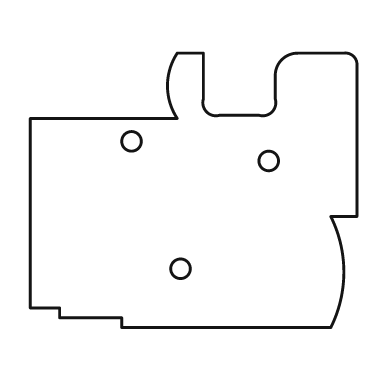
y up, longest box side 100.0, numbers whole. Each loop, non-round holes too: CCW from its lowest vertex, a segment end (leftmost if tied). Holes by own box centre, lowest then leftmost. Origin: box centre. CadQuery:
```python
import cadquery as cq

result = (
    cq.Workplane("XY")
    .moveTo(-22.0, -42.0)
    .lineTo(42.0, -42.0)
    .threePointArc((46.0, -25.0), (42.0, -8.0))
    .lineTo(50.0, -8.0)
    .lineTo(50.0, 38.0)
    .threePointArc((49.0, 41.0), (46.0, 42.0))
    .lineTo(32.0, 42.0)
    .threePointArc((27.0, 40.0), (25.0, 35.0))
    .lineTo(25.0, 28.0)
    .threePointArc((24.0, 24.0), (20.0, 23.0))
    .lineTo(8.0, 23.0)
    .threePointArc((4.0, 24.0), (3.0, 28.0))
    .lineTo(3.0, 42.0)
    .lineTo(-5.0, 42.0)
    .threePointArc((-8.0, 32.0), (-5.0, 22.0))
    .lineTo(-50.0, 22.0)
    .lineTo(-50.0, -36.0)
    .lineTo(-41.0, -36.0)
    .lineTo(-41.0, -39.0)
    .lineTo(-22.0, -39.0)
    .close()
    .moveTo(-4.0, -24.0)
    .circle(3.0)
    .moveTo(23.0, 9.0)
    .circle(3.0)
    .moveTo(-19.0, 15.0)
    .circle(3.0)
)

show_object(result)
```